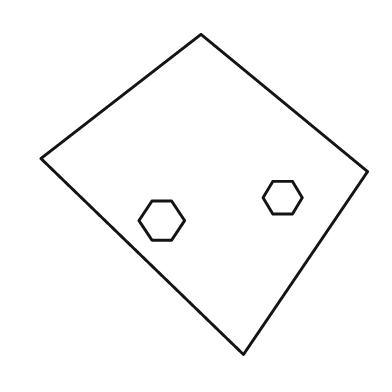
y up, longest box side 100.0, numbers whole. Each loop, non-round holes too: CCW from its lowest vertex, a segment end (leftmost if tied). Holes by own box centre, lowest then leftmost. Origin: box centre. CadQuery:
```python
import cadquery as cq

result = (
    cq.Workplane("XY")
    .moveTo(12.0, -49.0)
    .lineTo(50.0, 7.0)
    .lineTo(-1.0, 49.0)
    .lineTo(-50.0, 11.0)
    .close()
    .moveTo(-16.0, -14.0)
    .lineTo(-10.0, -14.0)
    .lineTo(-6.0, -8.0)
    .lineTo(-10.0, -2.0)
    .lineTo(-16.0, -2.0)
    .lineTo(-20.0, -8.0)
    .close()
    .moveTo(21.0, -6.0)
    .lineTo(27.0, -6.0)
    .lineTo(30.0, -1.0)
    .lineTo(27.0, 4.0)
    .lineTo(21.0, 4.0)
    .lineTo(18.0, -1.0)
    .close()
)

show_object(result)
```